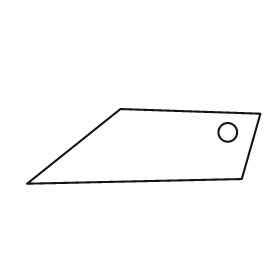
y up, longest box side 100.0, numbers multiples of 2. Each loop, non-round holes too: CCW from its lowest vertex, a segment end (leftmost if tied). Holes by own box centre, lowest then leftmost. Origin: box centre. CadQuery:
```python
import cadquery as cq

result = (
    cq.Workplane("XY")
    .moveTo(-50.0, -16.0)
    .lineTo(42.0, -14.0)
    .lineTo(50.0, 14.0)
    .lineTo(-10.0, 16.0)
    .close()
    .moveTo(36.0, 6.0)
    .circle(4.0)
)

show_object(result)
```